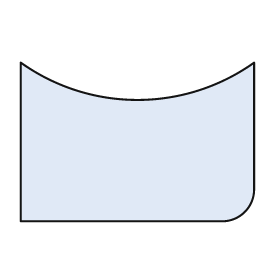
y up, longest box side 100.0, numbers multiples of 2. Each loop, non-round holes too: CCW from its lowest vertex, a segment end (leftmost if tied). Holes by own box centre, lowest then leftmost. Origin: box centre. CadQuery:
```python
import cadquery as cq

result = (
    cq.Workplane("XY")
    .moveTo(-50.0, -34.0)
    .lineTo(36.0, -34.0)
    .threePointArc((46.0, -30.0), (50.0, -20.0))
    .lineTo(50.0, 34.0)
    .threePointArc((0.0, 18.0), (-50.0, 34.0))
    .close()
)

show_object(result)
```